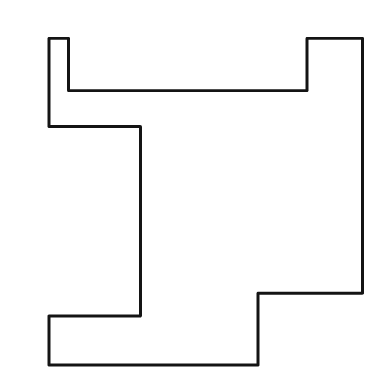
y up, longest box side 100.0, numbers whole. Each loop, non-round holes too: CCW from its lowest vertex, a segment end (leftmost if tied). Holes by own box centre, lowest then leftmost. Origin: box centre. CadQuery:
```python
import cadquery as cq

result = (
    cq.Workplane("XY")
    .moveTo(-48.0, -50.0)
    .lineTo(16.0, -50.0)
    .lineTo(16.0, -28.0)
    .lineTo(48.0, -28.0)
    .lineTo(48.0, 50.0)
    .lineTo(31.0, 50.0)
    .lineTo(31.0, 34.0)
    .lineTo(-42.0, 34.0)
    .lineTo(-42.0, 50.0)
    .lineTo(-48.0, 50.0)
    .lineTo(-48.0, 23.0)
    .lineTo(-20.0, 23.0)
    .lineTo(-20.0, -35.0)
    .lineTo(-48.0, -35.0)
    .close()
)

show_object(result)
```